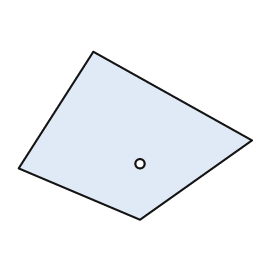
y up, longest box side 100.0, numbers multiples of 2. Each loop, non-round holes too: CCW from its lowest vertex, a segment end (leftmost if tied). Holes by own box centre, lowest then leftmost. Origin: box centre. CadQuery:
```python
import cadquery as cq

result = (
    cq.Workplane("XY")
    .moveTo(2.0, -36.0)
    .lineTo(50.0, -2.0)
    .lineTo(-18.0, 36.0)
    .lineTo(-50.0, -14.0)
    .close()
    .moveTo(2.0, -12.0)
    .circle(2.0)
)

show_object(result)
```